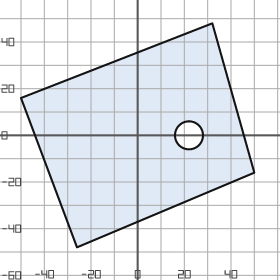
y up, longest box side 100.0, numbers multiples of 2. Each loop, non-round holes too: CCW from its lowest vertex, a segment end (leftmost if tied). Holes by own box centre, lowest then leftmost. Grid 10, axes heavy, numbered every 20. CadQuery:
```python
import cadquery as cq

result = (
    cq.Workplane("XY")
    .moveTo(-26.0, -48.0)
    .lineTo(50.0, -16.0)
    .lineTo(32.0, 48.0)
    .lineTo(-50.0, 16.0)
    .close()
    .moveTo(22.0, 0.0)
    .circle(6.0)
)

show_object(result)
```